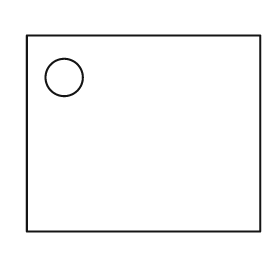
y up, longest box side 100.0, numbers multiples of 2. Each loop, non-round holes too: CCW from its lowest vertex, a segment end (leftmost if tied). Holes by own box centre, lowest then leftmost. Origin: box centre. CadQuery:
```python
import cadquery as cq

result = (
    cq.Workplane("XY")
    .moveTo(-50.0, -42.0)
    .lineTo(50.0, -42.0)
    .lineTo(50.0, 42.0)
    .lineTo(-50.0, 42.0)
    .close()
    .moveTo(-34.0, 24.0)
    .circle(8.0)
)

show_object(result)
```